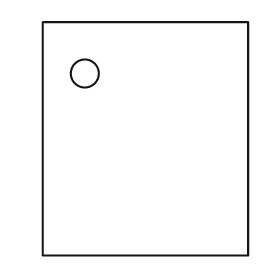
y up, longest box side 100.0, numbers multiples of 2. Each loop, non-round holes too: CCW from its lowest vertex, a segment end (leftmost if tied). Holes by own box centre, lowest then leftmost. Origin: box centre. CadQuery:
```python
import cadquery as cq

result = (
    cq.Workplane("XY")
    .moveTo(-44.0, -50.0)
    .lineTo(44.0, -50.0)
    .lineTo(44.0, 50.0)
    .lineTo(-44.0, 50.0)
    .close()
    .moveTo(-26.0, 28.0)
    .circle(6.0)
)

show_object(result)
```